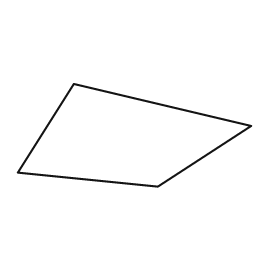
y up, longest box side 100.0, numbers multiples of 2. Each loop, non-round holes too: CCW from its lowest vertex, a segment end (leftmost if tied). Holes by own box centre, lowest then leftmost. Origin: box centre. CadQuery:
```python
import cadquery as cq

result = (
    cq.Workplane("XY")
    .moveTo(10.0, -22.0)
    .lineTo(50.0, 4.0)
    .lineTo(-26.0, 22.0)
    .lineTo(-50.0, -16.0)
    .close()
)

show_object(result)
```